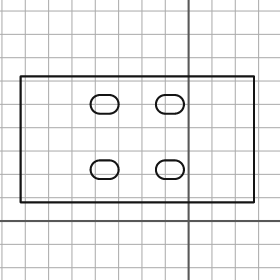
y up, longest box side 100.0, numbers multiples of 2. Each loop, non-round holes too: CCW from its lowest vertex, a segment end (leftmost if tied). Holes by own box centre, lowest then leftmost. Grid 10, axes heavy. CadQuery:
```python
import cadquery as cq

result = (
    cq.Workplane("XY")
    .moveTo(-72.0, 8.0)
    .lineTo(28.0, 8.0)
    .lineTo(28.0, 62.0)
    .lineTo(-72.0, 62.0)
    .close()
    .moveTo(-38.0, 18.0)
    .lineTo(-34.0, 18.0)
    .threePointArc((-30.0, 22.0), (-34.0, 26.0))
    .lineTo(-38.0, 26.0)
    .threePointArc((-42.0, 22.0), (-38.0, 18.0))
    .close()
    .moveTo(-10.0, 18.0)
    .lineTo(-6.0, 18.0)
    .threePointArc((-2.0, 22.0), (-6.0, 26.0))
    .lineTo(-10.0, 26.0)
    .threePointArc((-14.0, 22.0), (-10.0, 18.0))
    .close()
    .moveTo(-38.0, 46.0)
    .lineTo(-34.0, 46.0)
    .threePointArc((-30.0, 50.0), (-34.0, 54.0))
    .lineTo(-38.0, 54.0)
    .threePointArc((-42.0, 50.0), (-38.0, 46.0))
    .close()
    .moveTo(-10.0, 46.0)
    .lineTo(-6.0, 46.0)
    .threePointArc((-2.0, 50.0), (-6.0, 54.0))
    .lineTo(-10.0, 54.0)
    .threePointArc((-14.0, 50.0), (-10.0, 46.0))
    .close()
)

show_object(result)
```